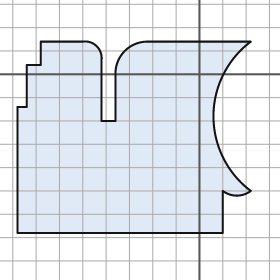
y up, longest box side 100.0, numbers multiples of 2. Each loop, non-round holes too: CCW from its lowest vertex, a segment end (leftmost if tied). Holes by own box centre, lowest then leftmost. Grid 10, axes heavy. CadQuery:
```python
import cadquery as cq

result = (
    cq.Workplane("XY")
    .moveTo(-78.0, -68.0)
    .lineTo(10.0, -68.0)
    .lineTo(10.0, -50.0)
    .threePointArc((16.0, -52.0), (22.0, -50.0))
    .threePointArc((6.0, -18.0), (22.0, 14.0))
    .lineTo(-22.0, 14.0)
    .threePointArc((-32.0, 10.0), (-36.0, 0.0))
    .lineTo(-36.0, -20.0)
    .lineTo(-42.0, -20.0)
    .lineTo(-42.0, 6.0)
    .threePointArc((-44.0, 12.0), (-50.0, 14.0))
    .lineTo(-68.0, 14.0)
    .lineTo(-68.0, 4.0)
    .lineTo(-74.0, 4.0)
    .lineTo(-74.0, -14.0)
    .lineTo(-78.0, -14.0)
    .close()
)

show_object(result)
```